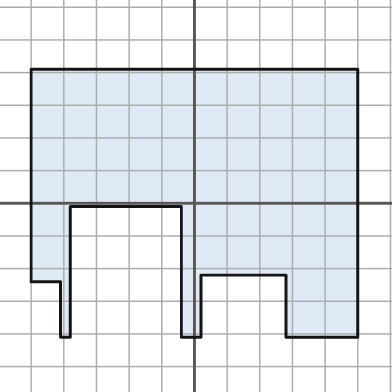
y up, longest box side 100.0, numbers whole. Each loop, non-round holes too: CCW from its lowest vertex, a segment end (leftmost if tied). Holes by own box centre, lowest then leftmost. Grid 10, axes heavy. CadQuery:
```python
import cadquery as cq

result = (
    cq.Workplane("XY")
    .moveTo(-41.0, -41.0)
    .lineTo(-38.0, -41.0)
    .lineTo(-38.0, -1.0)
    .lineTo(-4.0, -1.0)
    .lineTo(-4.0, -41.0)
    .lineTo(2.0, -41.0)
    .lineTo(2.0, -22.0)
    .lineTo(28.0, -22.0)
    .lineTo(28.0, -41.0)
    .lineTo(50.0, -41.0)
    .lineTo(50.0, 41.0)
    .lineTo(-50.0, 41.0)
    .lineTo(-50.0, -24.0)
    .lineTo(-41.0, -24.0)
    .close()
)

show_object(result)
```